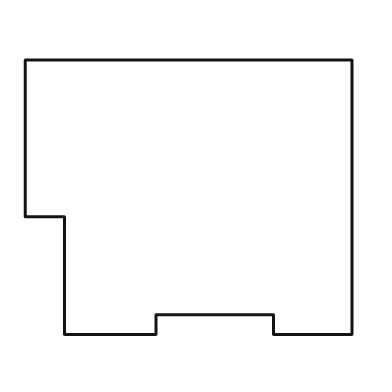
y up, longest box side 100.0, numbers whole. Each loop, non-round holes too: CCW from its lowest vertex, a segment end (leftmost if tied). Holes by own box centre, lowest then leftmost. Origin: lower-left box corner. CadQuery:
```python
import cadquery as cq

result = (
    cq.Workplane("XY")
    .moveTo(12.0, 0.0)
    .lineTo(40.0, 0.0)
    .lineTo(40.0, 6.0)
    .lineTo(76.0, 6.0)
    .lineTo(76.0, 0.0)
    .lineTo(100.0, 0.0)
    .lineTo(100.0, 84.0)
    .lineTo(0.0, 84.0)
    .lineTo(0.0, 36.0)
    .lineTo(12.0, 36.0)
    .close()
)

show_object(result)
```